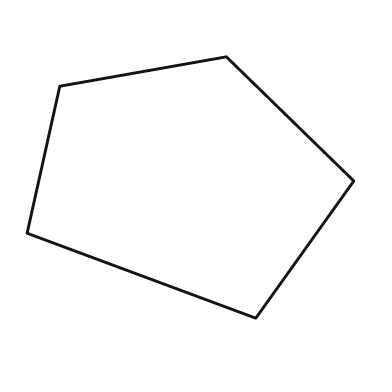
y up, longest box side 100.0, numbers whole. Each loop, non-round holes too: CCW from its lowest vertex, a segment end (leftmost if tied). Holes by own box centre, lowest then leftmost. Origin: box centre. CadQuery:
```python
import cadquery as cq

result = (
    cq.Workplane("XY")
    .moveTo(20.0, -40.0)
    .lineTo(50.0, 2.0)
    .lineTo(11.0, 40.0)
    .lineTo(-40.0, 31.0)
    .lineTo(-50.0, -14.0)
    .close()
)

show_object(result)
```